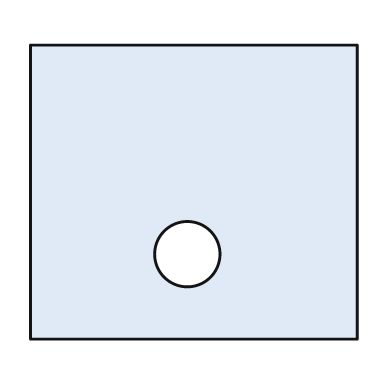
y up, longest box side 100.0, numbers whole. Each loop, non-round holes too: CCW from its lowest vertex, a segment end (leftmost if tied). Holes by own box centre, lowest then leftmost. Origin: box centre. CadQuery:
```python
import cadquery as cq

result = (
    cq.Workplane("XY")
    .moveTo(-50.0, -45.0)
    .lineTo(50.0, -45.0)
    .lineTo(50.0, 45.0)
    .lineTo(-50.0, 45.0)
    .close()
    .moveTo(-2.0, -19.0)
    .circle(10.0)
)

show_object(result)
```